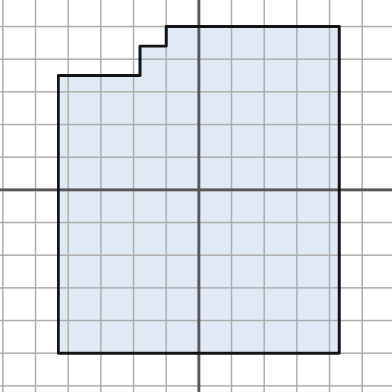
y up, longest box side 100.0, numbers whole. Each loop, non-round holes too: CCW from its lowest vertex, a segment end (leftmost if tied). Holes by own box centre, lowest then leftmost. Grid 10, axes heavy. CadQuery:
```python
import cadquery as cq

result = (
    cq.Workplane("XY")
    .moveTo(-43.0, -50.0)
    .lineTo(43.0, -50.0)
    .lineTo(43.0, 50.0)
    .lineTo(-10.0, 50.0)
    .lineTo(-10.0, 44.0)
    .lineTo(-18.0, 44.0)
    .lineTo(-18.0, 35.0)
    .lineTo(-43.0, 35.0)
    .close()
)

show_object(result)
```